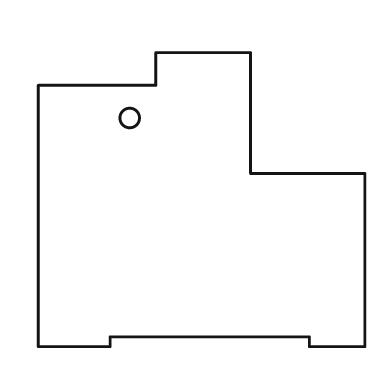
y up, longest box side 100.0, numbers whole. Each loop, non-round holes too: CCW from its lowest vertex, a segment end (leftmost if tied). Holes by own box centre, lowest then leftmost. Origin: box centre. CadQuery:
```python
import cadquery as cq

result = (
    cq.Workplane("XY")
    .moveTo(-50.0, -45.0)
    .lineTo(-28.0, -45.0)
    .lineTo(-28.0, -42.0)
    .lineTo(33.0, -42.0)
    .lineTo(33.0, -45.0)
    .lineTo(50.0, -45.0)
    .lineTo(50.0, 8.0)
    .lineTo(15.0, 8.0)
    .lineTo(15.0, 45.0)
    .lineTo(-14.0, 45.0)
    .lineTo(-14.0, 35.0)
    .lineTo(-50.0, 35.0)
    .close()
    .moveTo(-22.0, 25.0)
    .circle(3.0)
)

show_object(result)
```